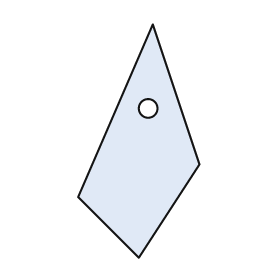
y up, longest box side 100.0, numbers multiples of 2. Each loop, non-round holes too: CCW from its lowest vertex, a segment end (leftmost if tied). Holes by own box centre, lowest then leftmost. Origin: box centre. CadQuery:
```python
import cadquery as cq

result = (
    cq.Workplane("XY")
    .moveTo(0.0, -50.0)
    .lineTo(26.0, -10.0)
    .lineTo(6.0, 50.0)
    .lineTo(-26.0, -24.0)
    .close()
    .moveTo(4.0, 14.0)
    .circle(4.0)
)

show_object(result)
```